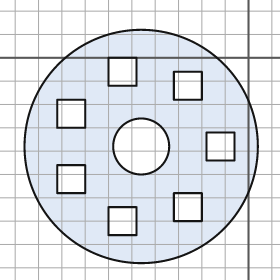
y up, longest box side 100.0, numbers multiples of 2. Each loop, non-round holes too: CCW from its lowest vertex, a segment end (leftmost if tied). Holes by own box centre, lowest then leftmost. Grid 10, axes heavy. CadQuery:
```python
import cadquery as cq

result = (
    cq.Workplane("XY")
    .moveTo(-46.0, -38.0)
    .circle(50.0)
    .moveTo(-60.0, -76.0)
    .lineTo(-48.0, -76.0)
    .lineTo(-48.0, -64.0)
    .lineTo(-60.0, -64.0)
    .close()
    .moveTo(-32.0, -70.0)
    .lineTo(-20.0, -70.0)
    .lineTo(-20.0, -58.0)
    .lineTo(-32.0, -58.0)
    .close()
    .moveTo(-82.0, -58.0)
    .lineTo(-70.0, -58.0)
    .lineTo(-70.0, -46.0)
    .lineTo(-82.0, -46.0)
    .close()
    .moveTo(-46.0, -38.0)
    .circle(12.0)
    .moveTo(-18.0, -44.0)
    .lineTo(-6.0, -44.0)
    .lineTo(-6.0, -32.0)
    .lineTo(-18.0, -32.0)
    .close()
    .moveTo(-82.0, -30.0)
    .lineTo(-70.0, -30.0)
    .lineTo(-70.0, -18.0)
    .lineTo(-82.0, -18.0)
    .close()
    .moveTo(-32.0, -18.0)
    .lineTo(-20.0, -18.0)
    .lineTo(-20.0, -6.0)
    .lineTo(-32.0, -6.0)
    .close()
    .moveTo(-60.0, -12.0)
    .lineTo(-48.0, -12.0)
    .lineTo(-48.0, 0.0)
    .lineTo(-60.0, 0.0)
    .close()
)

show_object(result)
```